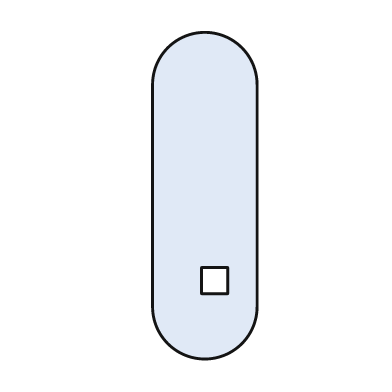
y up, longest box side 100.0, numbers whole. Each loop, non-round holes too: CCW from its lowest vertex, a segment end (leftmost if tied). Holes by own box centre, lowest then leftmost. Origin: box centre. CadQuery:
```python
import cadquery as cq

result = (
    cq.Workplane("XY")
    .moveTo(-16.0, -34.0)
    .threePointArc((0.0, -50.0), (16.0, -34.0))
    .lineTo(16.0, 34.0)
    .threePointArc((0.0, 50.0), (-16.0, 34.0))
    .close()
    .moveTo(-1.0, -30.0)
    .lineTo(7.0, -30.0)
    .lineTo(7.0, -22.0)
    .lineTo(-1.0, -22.0)
    .close()
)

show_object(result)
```